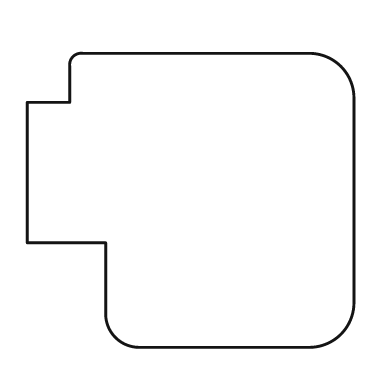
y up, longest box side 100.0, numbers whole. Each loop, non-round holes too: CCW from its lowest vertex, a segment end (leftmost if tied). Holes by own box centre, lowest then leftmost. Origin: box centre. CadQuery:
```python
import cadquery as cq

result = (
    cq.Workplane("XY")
    .moveTo(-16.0, -45.0)
    .lineTo(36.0, -45.0)
    .threePointArc((46.0, -41.0), (50.0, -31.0))
    .lineTo(50.0, 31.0)
    .threePointArc((46.0, 41.0), (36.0, 45.0))
    .lineTo(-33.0, 45.0)
    .threePointArc((-36.0, 44.0), (-37.0, 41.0))
    .lineTo(-37.0, 30.0)
    .lineTo(-50.0, 30.0)
    .lineTo(-50.0, -13.0)
    .lineTo(-26.0, -13.0)
    .lineTo(-26.0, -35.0)
    .threePointArc((-23.0, -42.0), (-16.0, -45.0))
    .close()
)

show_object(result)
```